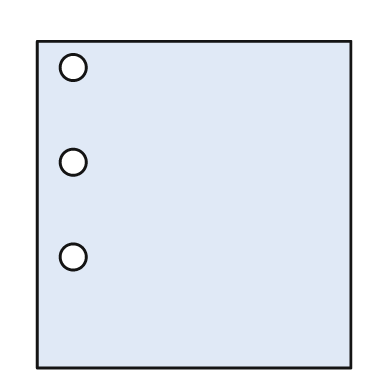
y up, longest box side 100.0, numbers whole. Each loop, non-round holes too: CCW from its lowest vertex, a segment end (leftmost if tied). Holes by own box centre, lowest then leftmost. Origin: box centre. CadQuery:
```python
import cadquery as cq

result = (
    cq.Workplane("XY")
    .moveTo(-48.0, -50.0)
    .lineTo(48.0, -50.0)
    .lineTo(48.0, 50.0)
    .lineTo(-48.0, 50.0)
    .close()
    .moveTo(-37.0, -16.0)
    .circle(4.0)
    .moveTo(-37.0, 13.0)
    .circle(4.0)
    .moveTo(-37.0, 42.0)
    .circle(4.0)
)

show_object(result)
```